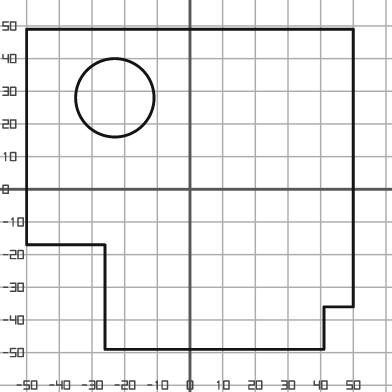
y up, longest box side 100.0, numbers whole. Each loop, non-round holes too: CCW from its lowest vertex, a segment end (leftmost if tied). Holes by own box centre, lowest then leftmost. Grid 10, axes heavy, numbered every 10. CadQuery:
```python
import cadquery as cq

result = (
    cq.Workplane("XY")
    .moveTo(-26.0, -49.0)
    .lineTo(41.0, -49.0)
    .lineTo(41.0, -36.0)
    .lineTo(50.0, -36.0)
    .lineTo(50.0, 49.0)
    .lineTo(-50.0, 49.0)
    .lineTo(-50.0, -17.0)
    .lineTo(-26.0, -17.0)
    .close()
    .moveTo(-23.0, 28.0)
    .circle(12.0)
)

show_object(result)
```